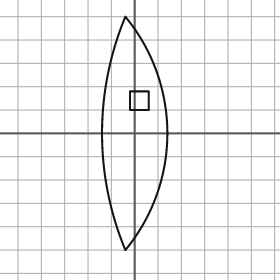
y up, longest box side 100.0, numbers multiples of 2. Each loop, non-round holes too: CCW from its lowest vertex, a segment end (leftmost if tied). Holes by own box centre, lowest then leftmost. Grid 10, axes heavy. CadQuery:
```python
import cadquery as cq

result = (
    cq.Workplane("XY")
    .moveTo(-4.0, -50.0)
    .threePointArc((14.0, 0.0), (-4.0, 50.0))
    .threePointArc((-14.0, 0.0), (-4.0, -50.0))
    .close()
    .moveTo(-2.0, 10.0)
    .lineTo(6.0, 10.0)
    .lineTo(6.0, 18.0)
    .lineTo(-2.0, 18.0)
    .close()
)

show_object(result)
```